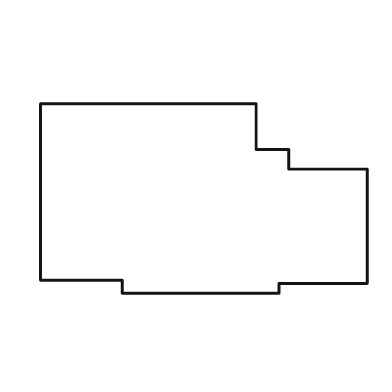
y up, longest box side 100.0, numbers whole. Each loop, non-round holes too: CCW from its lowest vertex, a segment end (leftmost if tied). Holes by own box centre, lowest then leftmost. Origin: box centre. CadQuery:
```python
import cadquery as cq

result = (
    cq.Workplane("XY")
    .moveTo(-25.0, -29.0)
    .lineTo(23.0, -29.0)
    .lineTo(23.0, -26.0)
    .lineTo(50.0, -26.0)
    .lineTo(50.0, 9.0)
    .lineTo(26.0, 9.0)
    .lineTo(26.0, 15.0)
    .lineTo(16.0, 15.0)
    .lineTo(16.0, 29.0)
    .lineTo(-50.0, 29.0)
    .lineTo(-50.0, -25.0)
    .lineTo(-25.0, -25.0)
    .close()
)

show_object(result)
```